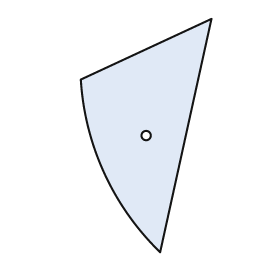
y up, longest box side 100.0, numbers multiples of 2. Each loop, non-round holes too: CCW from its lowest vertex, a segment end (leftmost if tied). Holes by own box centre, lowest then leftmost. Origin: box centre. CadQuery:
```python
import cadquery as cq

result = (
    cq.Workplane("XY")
    .moveTo(6.0, -50.0)
    .lineTo(28.0, 50.0)
    .lineTo(-28.0, 24.0)
    .threePointArc((-18.0, -16.0), (6.0, -50.0))
    .close()
    .moveTo(0.0, 0.0)
    .circle(2.0)
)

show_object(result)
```